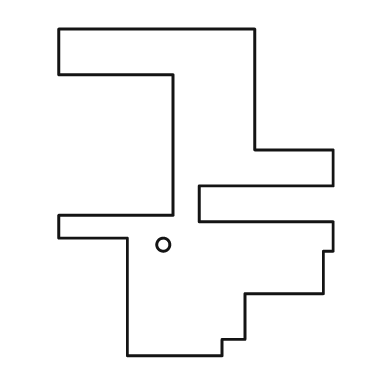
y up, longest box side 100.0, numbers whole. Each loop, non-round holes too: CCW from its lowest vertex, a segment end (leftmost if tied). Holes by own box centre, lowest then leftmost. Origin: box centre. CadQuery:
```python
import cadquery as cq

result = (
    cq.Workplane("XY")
    .moveTo(-21.0, -50.0)
    .lineTo(8.0, -50.0)
    .lineTo(8.0, -45.0)
    .lineTo(15.0, -45.0)
    .lineTo(15.0, -31.0)
    .lineTo(39.0, -31.0)
    .lineTo(39.0, -18.0)
    .lineTo(42.0, -18.0)
    .lineTo(42.0, -9.0)
    .lineTo(1.0, -9.0)
    .lineTo(1.0, 2.0)
    .lineTo(42.0, 2.0)
    .lineTo(42.0, 13.0)
    .lineTo(18.0, 13.0)
    .lineTo(18.0, 50.0)
    .lineTo(-42.0, 50.0)
    .lineTo(-42.0, 36.0)
    .lineTo(-7.0, 36.0)
    .lineTo(-7.0, -7.0)
    .lineTo(-42.0, -7.0)
    .lineTo(-42.0, -14.0)
    .lineTo(-21.0, -14.0)
    .close()
    .moveTo(-10.0, -16.0)
    .circle(2.0)
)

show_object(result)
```